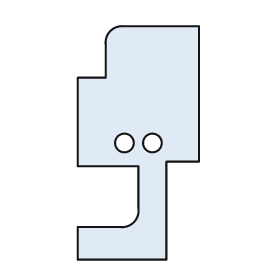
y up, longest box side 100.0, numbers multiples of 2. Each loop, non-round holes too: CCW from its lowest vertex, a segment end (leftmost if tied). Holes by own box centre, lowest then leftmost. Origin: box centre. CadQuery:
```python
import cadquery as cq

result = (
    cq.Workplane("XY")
    .moveTo(-26.0, -50.0)
    .lineTo(12.0, -50.0)
    .lineTo(12.0, -8.0)
    .lineTo(26.0, -8.0)
    .lineTo(26.0, 50.0)
    .lineTo(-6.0, 50.0)
    .threePointArc((-12.0, 48.0), (-14.0, 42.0))
    .lineTo(-14.0, 28.0)
    .lineTo(-26.0, 28.0)
    .lineTo(-26.0, -10.0)
    .lineTo(0.0, -10.0)
    .lineTo(0.0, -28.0)
    .threePointArc((-2.0, -34.0), (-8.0, -36.0))
    .lineTo(-26.0, -36.0)
    .close()
    .moveTo(-6.0, 0.0)
    .circle(4.0)
    .moveTo(6.0, 0.0)
    .circle(4.0)
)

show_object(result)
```